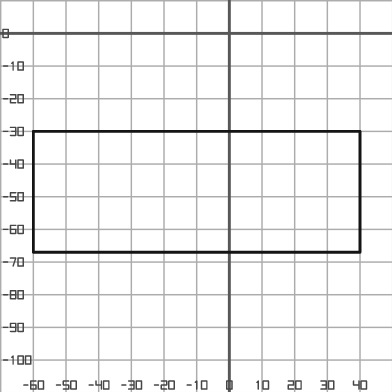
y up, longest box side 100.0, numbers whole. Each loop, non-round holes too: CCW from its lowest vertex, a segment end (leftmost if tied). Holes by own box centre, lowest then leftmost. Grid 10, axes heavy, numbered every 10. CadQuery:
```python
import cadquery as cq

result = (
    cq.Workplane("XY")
    .moveTo(-60.0, -67.0)
    .lineTo(40.0, -67.0)
    .lineTo(40.0, -30.0)
    .lineTo(-60.0, -30.0)
    .close()
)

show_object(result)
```